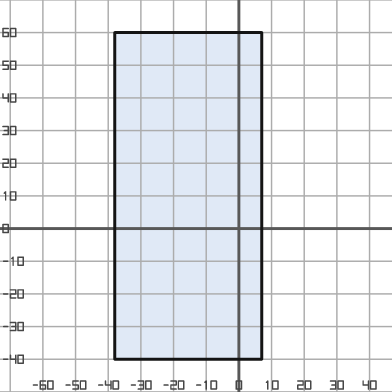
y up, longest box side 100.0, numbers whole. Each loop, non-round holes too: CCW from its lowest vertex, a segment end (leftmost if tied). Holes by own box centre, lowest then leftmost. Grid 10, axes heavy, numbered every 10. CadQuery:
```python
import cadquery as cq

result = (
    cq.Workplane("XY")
    .moveTo(-38.0, -40.0)
    .lineTo(7.0, -40.0)
    .lineTo(7.0, 60.0)
    .lineTo(-38.0, 60.0)
    .close()
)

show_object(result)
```